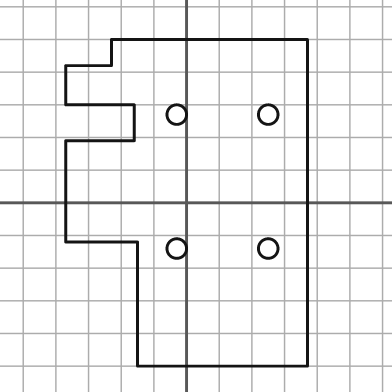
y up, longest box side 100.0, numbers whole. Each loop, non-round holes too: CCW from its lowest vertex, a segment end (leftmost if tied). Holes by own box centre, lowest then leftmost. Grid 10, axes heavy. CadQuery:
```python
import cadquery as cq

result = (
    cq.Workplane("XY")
    .moveTo(-15.0, -50.0)
    .lineTo(37.0, -50.0)
    .lineTo(37.0, 50.0)
    .lineTo(-23.0, 50.0)
    .lineTo(-23.0, 42.0)
    .lineTo(-37.0, 42.0)
    .lineTo(-37.0, 30.0)
    .lineTo(-16.0, 30.0)
    .lineTo(-16.0, 19.0)
    .lineTo(-37.0, 19.0)
    .lineTo(-37.0, -12.0)
    .lineTo(-15.0, -12.0)
    .close()
    .moveTo(-3.0, -14.0)
    .circle(3.0)
    .moveTo(25.0, -14.0)
    .circle(3.0)
    .moveTo(-3.0, 27.0)
    .circle(3.0)
    .moveTo(25.0, 27.0)
    .circle(3.0)
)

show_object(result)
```